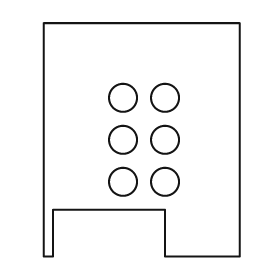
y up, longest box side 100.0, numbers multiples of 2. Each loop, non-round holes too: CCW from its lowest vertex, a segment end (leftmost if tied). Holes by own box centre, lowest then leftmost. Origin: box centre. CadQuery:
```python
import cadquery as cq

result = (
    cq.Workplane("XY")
    .moveTo(-42.0, -50.0)
    .lineTo(-38.0, -50.0)
    .lineTo(-38.0, -30.0)
    .lineTo(10.0, -30.0)
    .lineTo(10.0, -50.0)
    .lineTo(42.0, -50.0)
    .lineTo(42.0, 50.0)
    .lineTo(-42.0, 50.0)
    .close()
    .moveTo(-8.0, -18.0)
    .circle(6.0)
    .moveTo(10.0, -18.0)
    .circle(6.0)
    .moveTo(-8.0, 0.0)
    .circle(6.0)
    .moveTo(10.0, 0.0)
    .circle(6.0)
    .moveTo(-8.0, 18.0)
    .circle(6.0)
    .moveTo(10.0, 18.0)
    .circle(6.0)
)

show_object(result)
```